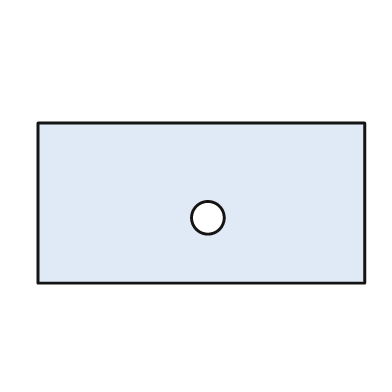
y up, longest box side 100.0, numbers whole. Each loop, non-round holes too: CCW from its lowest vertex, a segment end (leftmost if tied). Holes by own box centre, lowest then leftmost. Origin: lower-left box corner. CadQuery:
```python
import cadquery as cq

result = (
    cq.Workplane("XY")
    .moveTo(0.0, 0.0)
    .lineTo(100.0, 0.0)
    .lineTo(100.0, 49.0)
    .lineTo(0.0, 49.0)
    .close()
    .moveTo(52.0, 20.0)
    .circle(5.0)
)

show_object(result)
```